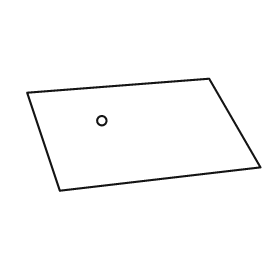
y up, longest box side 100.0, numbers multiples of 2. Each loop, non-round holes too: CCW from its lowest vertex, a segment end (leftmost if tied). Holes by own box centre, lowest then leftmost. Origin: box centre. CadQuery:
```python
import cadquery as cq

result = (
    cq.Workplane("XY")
    .moveTo(-36.0, -24.0)
    .lineTo(50.0, -14.0)
    .lineTo(28.0, 24.0)
    .lineTo(-50.0, 18.0)
    .close()
    .moveTo(-18.0, 6.0)
    .circle(2.0)
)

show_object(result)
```